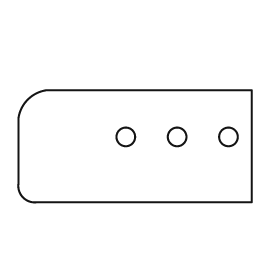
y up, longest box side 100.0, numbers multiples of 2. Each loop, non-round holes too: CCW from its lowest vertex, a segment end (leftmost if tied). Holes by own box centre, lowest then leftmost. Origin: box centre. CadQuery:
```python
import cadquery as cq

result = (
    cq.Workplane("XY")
    .moveTo(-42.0, -24.0)
    .lineTo(50.0, -24.0)
    .lineTo(50.0, 24.0)
    .lineTo(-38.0, 24.0)
    .threePointArc((-46.0, 20.0), (-50.0, 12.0))
    .lineTo(-50.0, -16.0)
    .threePointArc((-48.0, -22.0), (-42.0, -24.0))
    .close()
    .moveTo(-4.0, 4.0)
    .circle(4.0)
    .moveTo(18.0, 4.0)
    .circle(4.0)
    .moveTo(40.0, 4.0)
    .circle(4.0)
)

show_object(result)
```